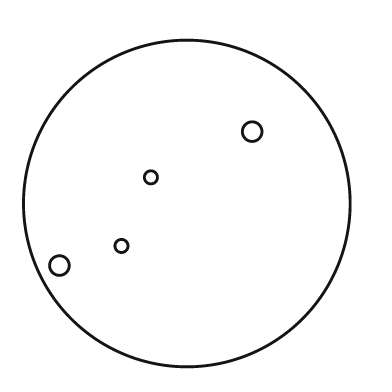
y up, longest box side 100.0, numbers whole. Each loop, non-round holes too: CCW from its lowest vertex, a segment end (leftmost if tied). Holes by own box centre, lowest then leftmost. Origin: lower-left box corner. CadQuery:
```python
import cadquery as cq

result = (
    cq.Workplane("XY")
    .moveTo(50.0, 50.0)
    .circle(50.0)
    .moveTo(11.0, 31.0)
    .circle(3.0)
    .moveTo(30.0, 37.0)
    .circle(2.0)
    .moveTo(39.0, 58.0)
    .circle(2.0)
    .moveTo(70.0, 72.0)
    .circle(3.0)
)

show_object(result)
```